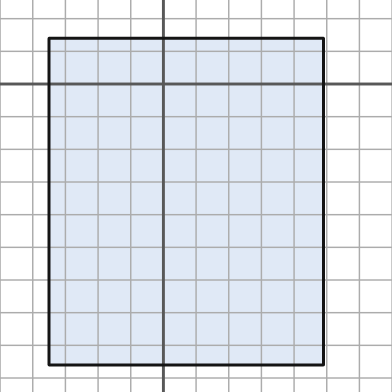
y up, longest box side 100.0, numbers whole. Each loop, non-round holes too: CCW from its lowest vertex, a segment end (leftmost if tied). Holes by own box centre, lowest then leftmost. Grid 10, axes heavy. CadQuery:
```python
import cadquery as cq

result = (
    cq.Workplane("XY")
    .moveTo(-35.0, -86.0)
    .lineTo(49.0, -86.0)
    .lineTo(49.0, 14.0)
    .lineTo(-35.0, 14.0)
    .close()
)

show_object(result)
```